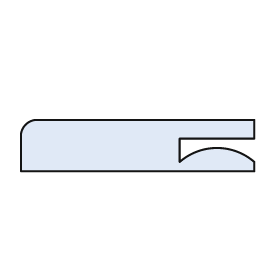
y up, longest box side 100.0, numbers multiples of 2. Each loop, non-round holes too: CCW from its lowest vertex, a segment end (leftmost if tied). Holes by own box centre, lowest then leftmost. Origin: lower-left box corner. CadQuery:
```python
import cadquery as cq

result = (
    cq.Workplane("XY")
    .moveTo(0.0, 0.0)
    .lineTo(100.0, 0.0)
    .lineTo(100.0, 4.0)
    .threePointArc((84.0, 10.0), (68.0, 4.0))
    .lineTo(68.0, 14.0)
    .lineTo(100.0, 14.0)
    .lineTo(100.0, 22.0)
    .lineTo(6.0, 22.0)
    .threePointArc((2.0, 20.0), (0.0, 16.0))
    .close()
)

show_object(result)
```